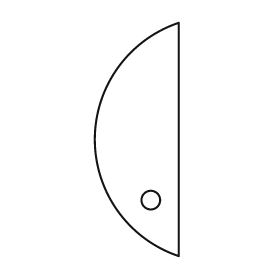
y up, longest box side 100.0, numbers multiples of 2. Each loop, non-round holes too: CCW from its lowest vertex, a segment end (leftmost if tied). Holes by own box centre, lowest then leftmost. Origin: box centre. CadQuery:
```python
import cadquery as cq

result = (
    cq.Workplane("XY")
    .moveTo(18.0, -50.0)
    .lineTo(18.0, 50.0)
    .threePointArc((-18.0, 0.0), (18.0, -50.0))
    .close()
    .moveTo(6.0, -26.0)
    .circle(4.0)
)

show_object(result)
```